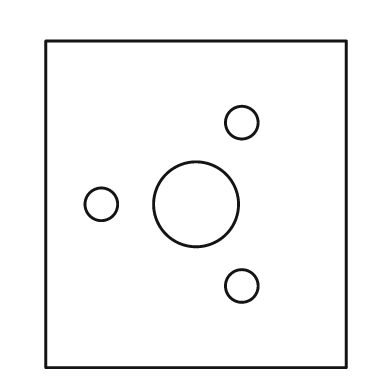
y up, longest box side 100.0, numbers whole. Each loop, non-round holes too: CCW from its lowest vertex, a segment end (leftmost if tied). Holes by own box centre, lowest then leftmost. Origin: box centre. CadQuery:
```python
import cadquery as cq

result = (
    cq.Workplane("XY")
    .moveTo(-46.0, -50.0)
    .lineTo(46.0, -50.0)
    .lineTo(46.0, 50.0)
    .lineTo(-46.0, 50.0)
    .close()
    .moveTo(14.0, -25.0)
    .circle(5.0)
    .moveTo(-29.0, 0.0)
    .circle(5.0)
    .moveTo(0.0, 0.0)
    .circle(13.0)
    .moveTo(14.0, 25.0)
    .circle(5.0)
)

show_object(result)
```